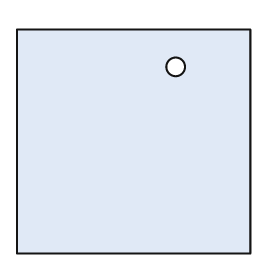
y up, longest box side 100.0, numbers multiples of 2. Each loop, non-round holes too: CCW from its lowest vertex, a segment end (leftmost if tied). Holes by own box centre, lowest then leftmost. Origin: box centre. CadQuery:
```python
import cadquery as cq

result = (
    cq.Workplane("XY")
    .moveTo(-50.0, -48.0)
    .lineTo(50.0, -48.0)
    .lineTo(50.0, 48.0)
    .lineTo(-50.0, 48.0)
    .close()
    .moveTo(18.0, 32.0)
    .circle(4.0)
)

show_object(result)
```